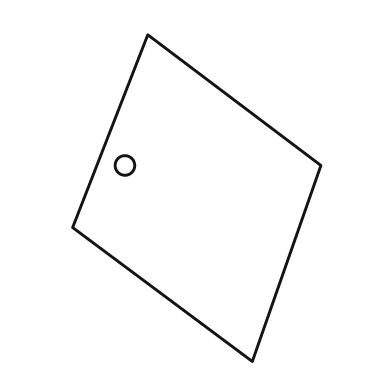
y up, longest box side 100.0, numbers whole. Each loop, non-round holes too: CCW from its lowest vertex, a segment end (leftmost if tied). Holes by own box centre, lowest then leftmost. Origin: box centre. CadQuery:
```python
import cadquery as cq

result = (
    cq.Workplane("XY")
    .moveTo(17.0, -50.0)
    .lineTo(38.0, 10.0)
    .lineTo(-15.0, 50.0)
    .lineTo(-38.0, -9.0)
    .close()
    .moveTo(-22.0, 10.0)
    .circle(3.0)
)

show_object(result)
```